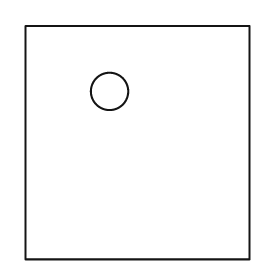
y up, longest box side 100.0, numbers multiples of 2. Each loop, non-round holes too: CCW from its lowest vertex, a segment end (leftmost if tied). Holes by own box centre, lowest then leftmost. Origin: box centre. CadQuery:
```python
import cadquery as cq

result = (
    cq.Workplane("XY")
    .moveTo(-48.0, -50.0)
    .lineTo(48.0, -50.0)
    .lineTo(48.0, 50.0)
    .lineTo(-48.0, 50.0)
    .close()
    .moveTo(-12.0, 22.0)
    .circle(8.0)
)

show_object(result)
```